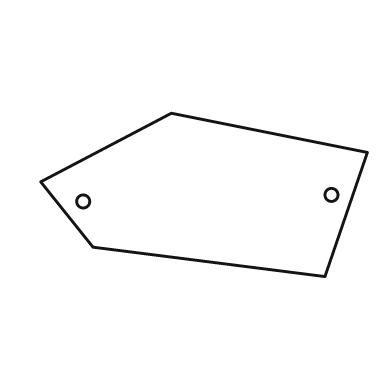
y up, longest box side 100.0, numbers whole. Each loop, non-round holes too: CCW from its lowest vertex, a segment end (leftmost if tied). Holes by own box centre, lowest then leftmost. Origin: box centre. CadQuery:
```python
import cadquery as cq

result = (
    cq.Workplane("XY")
    .moveTo(37.0, -25.0)
    .lineTo(50.0, 13.0)
    .lineTo(-10.0, 25.0)
    .lineTo(-50.0, 4.0)
    .lineTo(-34.0, -16.0)
    .close()
    .moveTo(-37.0, -2.0)
    .circle(2.0)
    .moveTo(39.0, 0.0)
    .circle(2.0)
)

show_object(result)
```